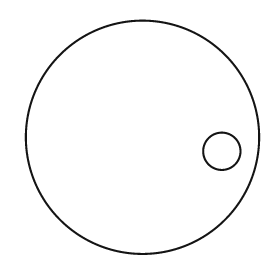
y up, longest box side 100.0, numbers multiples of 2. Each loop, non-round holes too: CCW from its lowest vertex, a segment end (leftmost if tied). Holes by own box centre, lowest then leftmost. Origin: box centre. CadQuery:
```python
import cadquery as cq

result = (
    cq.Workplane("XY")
    .moveTo(0.0, 0.0)
    .circle(50.0)
    .moveTo(34.0, -6.0)
    .circle(8.0)
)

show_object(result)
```